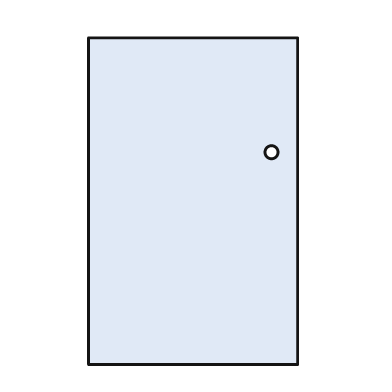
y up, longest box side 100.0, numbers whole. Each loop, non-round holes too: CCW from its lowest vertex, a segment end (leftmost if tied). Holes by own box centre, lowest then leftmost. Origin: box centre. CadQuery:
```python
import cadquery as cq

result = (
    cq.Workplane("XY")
    .moveTo(-32.0, -50.0)
    .lineTo(32.0, -50.0)
    .lineTo(32.0, 50.0)
    .lineTo(-32.0, 50.0)
    .close()
    .moveTo(24.0, 15.0)
    .circle(2.0)
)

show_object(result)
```